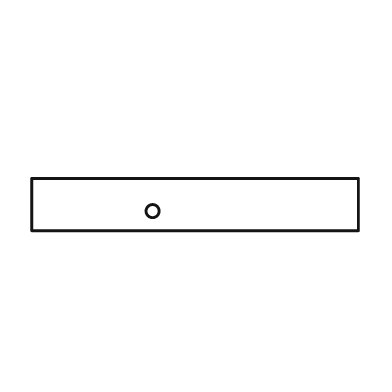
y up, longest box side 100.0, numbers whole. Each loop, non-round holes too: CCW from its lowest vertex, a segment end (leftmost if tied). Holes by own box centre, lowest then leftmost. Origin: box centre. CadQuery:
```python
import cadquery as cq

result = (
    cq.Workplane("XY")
    .moveTo(-50.0, -8.0)
    .lineTo(50.0, -8.0)
    .lineTo(50.0, 8.0)
    .lineTo(-50.0, 8.0)
    .close()
    .moveTo(-13.0, -2.0)
    .circle(2.0)
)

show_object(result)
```